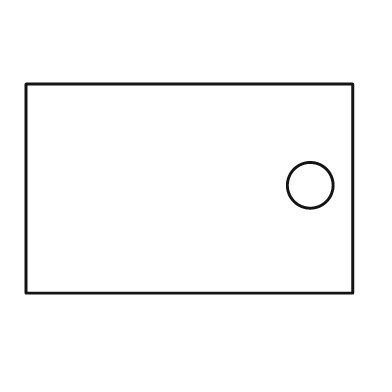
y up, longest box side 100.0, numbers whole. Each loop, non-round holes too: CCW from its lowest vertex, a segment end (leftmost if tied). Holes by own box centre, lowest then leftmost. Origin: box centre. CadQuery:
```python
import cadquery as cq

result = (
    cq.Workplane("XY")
    .moveTo(-50.0, -32.0)
    .lineTo(50.0, -32.0)
    .lineTo(50.0, 32.0)
    .lineTo(-50.0, 32.0)
    .close()
    .moveTo(37.0, 1.0)
    .circle(7.0)
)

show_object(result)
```